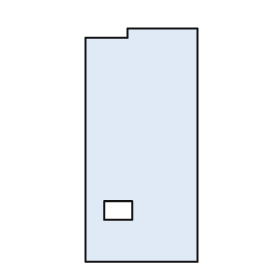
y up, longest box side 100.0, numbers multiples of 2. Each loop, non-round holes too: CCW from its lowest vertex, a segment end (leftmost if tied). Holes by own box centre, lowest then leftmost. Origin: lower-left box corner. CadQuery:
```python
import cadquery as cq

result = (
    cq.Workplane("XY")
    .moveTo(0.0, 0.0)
    .lineTo(48.0, 0.0)
    .lineTo(48.0, 100.0)
    .lineTo(18.0, 100.0)
    .lineTo(18.0, 96.0)
    .lineTo(0.0, 96.0)
    .close()
    .moveTo(8.0, 18.0)
    .lineTo(20.0, 18.0)
    .lineTo(20.0, 26.0)
    .lineTo(8.0, 26.0)
    .close()
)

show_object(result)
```